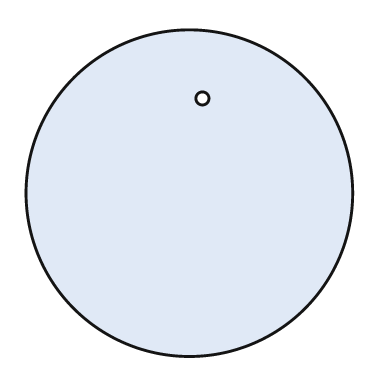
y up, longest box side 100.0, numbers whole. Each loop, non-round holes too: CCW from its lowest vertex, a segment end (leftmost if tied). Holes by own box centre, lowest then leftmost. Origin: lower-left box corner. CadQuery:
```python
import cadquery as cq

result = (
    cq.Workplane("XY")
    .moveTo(50.0, 50.0)
    .circle(50.0)
    .moveTo(54.0, 79.0)
    .circle(2.0)
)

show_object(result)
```